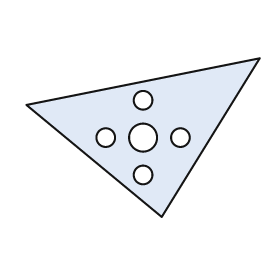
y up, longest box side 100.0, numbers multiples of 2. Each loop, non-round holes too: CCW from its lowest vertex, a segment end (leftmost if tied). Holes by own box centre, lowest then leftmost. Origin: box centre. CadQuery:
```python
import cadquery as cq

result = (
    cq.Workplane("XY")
    .moveTo(8.0, -34.0)
    .lineTo(50.0, 34.0)
    .lineTo(-50.0, 14.0)
    .close()
    .moveTo(0.0, -16.0)
    .circle(4.0)
    .moveTo(-16.0, 0.0)
    .circle(4.0)
    .moveTo(0.0, 0.0)
    .circle(6.0)
    .moveTo(16.0, 0.0)
    .circle(4.0)
    .moveTo(0.0, 16.0)
    .circle(4.0)
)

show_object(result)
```